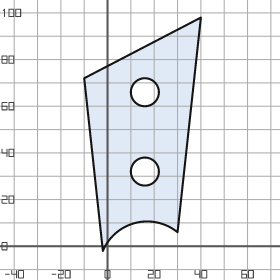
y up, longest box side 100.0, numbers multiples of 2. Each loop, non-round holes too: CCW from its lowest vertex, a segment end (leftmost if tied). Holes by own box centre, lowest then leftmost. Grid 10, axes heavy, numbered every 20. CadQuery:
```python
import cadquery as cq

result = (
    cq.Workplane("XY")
    .moveTo(-2.0, -2.0)
    .threePointArc((12.0, 10.0), (30.0, 6.0))
    .lineTo(40.0, 98.0)
    .lineTo(-10.0, 72.0)
    .close()
    .moveTo(16.0, 32.0)
    .circle(6.0)
    .moveTo(16.0, 66.0)
    .circle(6.0)
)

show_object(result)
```